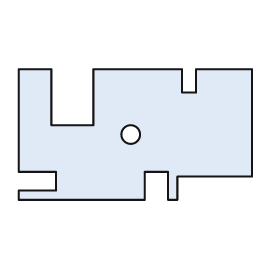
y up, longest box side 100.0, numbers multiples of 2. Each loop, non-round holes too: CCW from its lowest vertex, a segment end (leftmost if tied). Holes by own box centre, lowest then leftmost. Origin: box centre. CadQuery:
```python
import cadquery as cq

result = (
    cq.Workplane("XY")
    .moveTo(-50.0, -28.0)
    .lineTo(4.0, -28.0)
    .lineTo(4.0, -16.0)
    .lineTo(14.0, -16.0)
    .lineTo(14.0, -28.0)
    .lineTo(18.0, -28.0)
    .lineTo(18.0, -18.0)
    .lineTo(50.0, -18.0)
    .lineTo(50.0, 28.0)
    .lineTo(26.0, 28.0)
    .lineTo(26.0, 18.0)
    .lineTo(20.0, 18.0)
    .lineTo(20.0, 28.0)
    .lineTo(-18.0, 28.0)
    .lineTo(-18.0, 4.0)
    .lineTo(-36.0, 4.0)
    .lineTo(-36.0, 28.0)
    .lineTo(-50.0, 28.0)
    .lineTo(-50.0, -16.0)
    .lineTo(-34.0, -16.0)
    .lineTo(-34.0, -24.0)
    .lineTo(-50.0, -24.0)
    .close()
    .moveTo(-2.0, 0.0)
    .circle(4.0)
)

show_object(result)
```